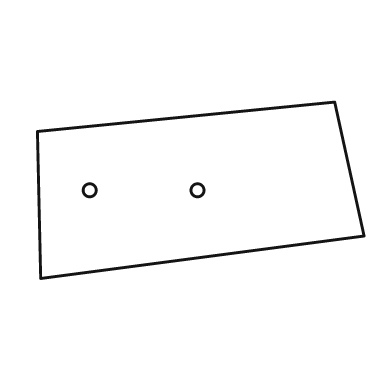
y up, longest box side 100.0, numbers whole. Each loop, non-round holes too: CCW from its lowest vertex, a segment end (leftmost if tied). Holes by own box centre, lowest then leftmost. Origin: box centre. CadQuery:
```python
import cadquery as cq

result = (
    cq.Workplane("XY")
    .moveTo(-49.0, -27.0)
    .lineTo(50.0, -14.0)
    .lineTo(41.0, 27.0)
    .lineTo(-50.0, 18.0)
    .close()
    .moveTo(-34.0, 0.0)
    .circle(2.0)
    .moveTo(-1.0, 0.0)
    .circle(2.0)
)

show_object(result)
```